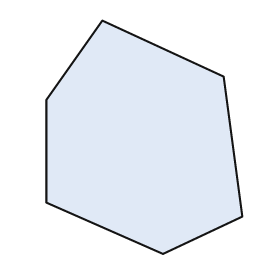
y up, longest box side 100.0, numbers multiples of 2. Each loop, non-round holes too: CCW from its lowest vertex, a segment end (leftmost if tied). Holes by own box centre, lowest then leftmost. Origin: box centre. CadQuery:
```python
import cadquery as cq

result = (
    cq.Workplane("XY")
    .moveTo(8.0, -50.0)
    .lineTo(42.0, -34.0)
    .lineTo(34.0, 26.0)
    .lineTo(-18.0, 50.0)
    .lineTo(-42.0, 16.0)
    .lineTo(-42.0, -28.0)
    .close()
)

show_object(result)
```